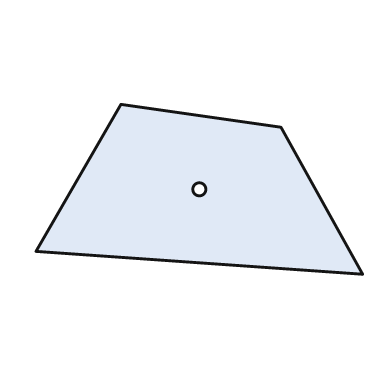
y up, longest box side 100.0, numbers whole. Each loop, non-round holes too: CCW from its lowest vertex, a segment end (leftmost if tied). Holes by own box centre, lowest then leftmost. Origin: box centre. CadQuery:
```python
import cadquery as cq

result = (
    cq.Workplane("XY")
    .moveTo(50.0, -26.0)
    .lineTo(25.0, 19.0)
    .lineTo(-24.0, 26.0)
    .lineTo(-50.0, -19.0)
    .close()
    .moveTo(0.0, 0.0)
    .circle(2.0)
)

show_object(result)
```